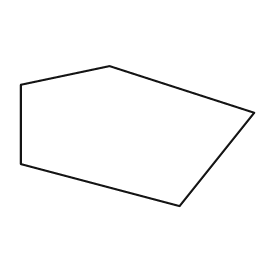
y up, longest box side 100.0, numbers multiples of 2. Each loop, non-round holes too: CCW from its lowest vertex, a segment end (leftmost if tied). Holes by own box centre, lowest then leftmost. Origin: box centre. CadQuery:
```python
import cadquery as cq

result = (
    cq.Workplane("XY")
    .moveTo(18.0, -30.0)
    .lineTo(50.0, 10.0)
    .lineTo(-12.0, 30.0)
    .lineTo(-50.0, 22.0)
    .lineTo(-50.0, -12.0)
    .close()
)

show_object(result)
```